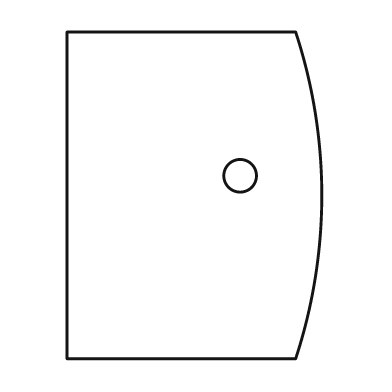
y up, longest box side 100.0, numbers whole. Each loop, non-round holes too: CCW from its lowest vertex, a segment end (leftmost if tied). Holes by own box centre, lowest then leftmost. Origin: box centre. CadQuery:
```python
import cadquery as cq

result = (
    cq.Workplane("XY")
    .moveTo(-39.0, -50.0)
    .lineTo(31.0, -50.0)
    .threePointArc((39.0, 0.0), (31.0, 50.0))
    .lineTo(-39.0, 50.0)
    .close()
    .moveTo(14.0, 6.0)
    .circle(5.0)
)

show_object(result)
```